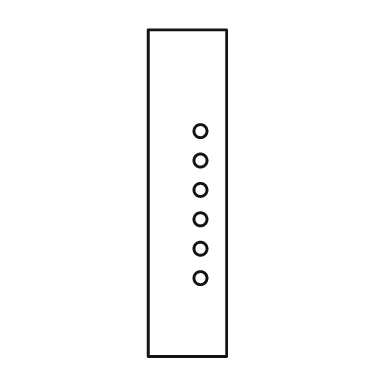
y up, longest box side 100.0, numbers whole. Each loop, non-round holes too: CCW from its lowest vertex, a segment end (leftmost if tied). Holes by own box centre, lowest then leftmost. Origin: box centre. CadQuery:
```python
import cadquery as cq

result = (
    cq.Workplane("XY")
    .moveTo(-12.0, -50.0)
    .lineTo(12.0, -50.0)
    .lineTo(12.0, 50.0)
    .lineTo(-12.0, 50.0)
    .close()
    .moveTo(4.0, -26.0)
    .circle(2.0)
    .moveTo(4.0, -17.0)
    .circle(2.0)
    .moveTo(4.0, -8.0)
    .circle(2.0)
    .moveTo(4.0, 1.0)
    .circle(2.0)
    .moveTo(4.0, 10.0)
    .circle(2.0)
    .moveTo(4.0, 19.0)
    .circle(2.0)
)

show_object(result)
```